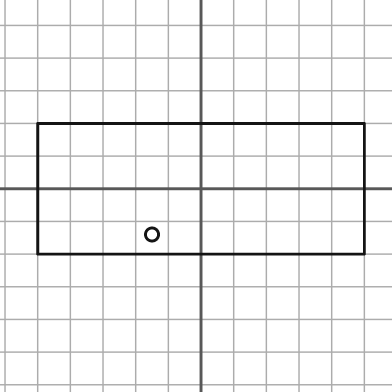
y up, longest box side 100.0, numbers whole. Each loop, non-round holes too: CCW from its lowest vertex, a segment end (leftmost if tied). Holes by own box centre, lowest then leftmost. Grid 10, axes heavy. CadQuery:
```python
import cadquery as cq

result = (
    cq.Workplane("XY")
    .moveTo(-50.0, -20.0)
    .lineTo(50.0, -20.0)
    .lineTo(50.0, 20.0)
    .lineTo(-50.0, 20.0)
    .close()
    .moveTo(-15.0, -14.0)
    .circle(2.0)
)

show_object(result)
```